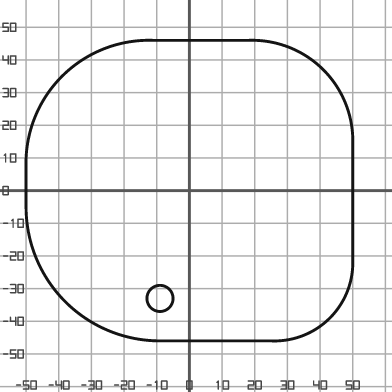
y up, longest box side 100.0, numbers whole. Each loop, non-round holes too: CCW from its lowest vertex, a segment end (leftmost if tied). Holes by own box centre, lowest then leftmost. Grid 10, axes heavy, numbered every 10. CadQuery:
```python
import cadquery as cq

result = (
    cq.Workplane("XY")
    .moveTo(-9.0, -46.0)
    .lineTo(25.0, -46.0)
    .threePointArc((43.0, -39.0), (50.0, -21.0))
    .lineTo(50.0, 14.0)
    .threePointArc((41.0, 37.0), (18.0, 46.0))
    .lineTo(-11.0, 46.0)
    .threePointArc((-39.0, 35.0), (-50.0, 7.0))
    .lineTo(-50.0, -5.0)
    .threePointArc((-38.0, -34.0), (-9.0, -46.0))
    .close()
    .moveTo(-9.0, -33.0)
    .circle(4.0)
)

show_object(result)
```